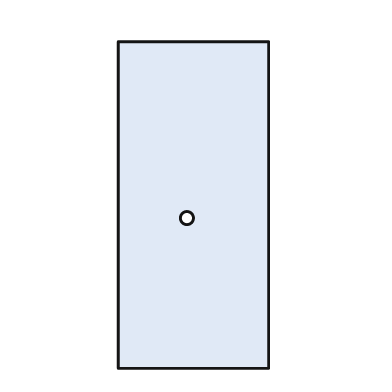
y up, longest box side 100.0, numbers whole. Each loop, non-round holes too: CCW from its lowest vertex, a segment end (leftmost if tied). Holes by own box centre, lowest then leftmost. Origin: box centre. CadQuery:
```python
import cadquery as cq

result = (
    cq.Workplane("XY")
    .moveTo(-23.0, -50.0)
    .lineTo(23.0, -50.0)
    .lineTo(23.0, 50.0)
    .lineTo(-23.0, 50.0)
    .close()
    .moveTo(-2.0, -4.0)
    .circle(2.0)
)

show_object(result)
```